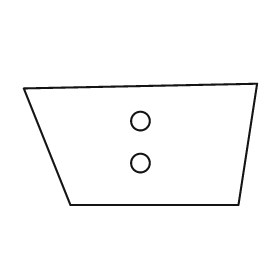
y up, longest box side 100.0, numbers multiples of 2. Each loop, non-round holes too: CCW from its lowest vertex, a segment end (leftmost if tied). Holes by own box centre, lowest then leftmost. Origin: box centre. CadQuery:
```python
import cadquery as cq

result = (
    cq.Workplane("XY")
    .moveTo(-30.0, -26.0)
    .lineTo(42.0, -26.0)
    .lineTo(50.0, 26.0)
    .lineTo(-50.0, 24.0)
    .close()
    .moveTo(0.0, -8.0)
    .circle(4.0)
    .moveTo(0.0, 10.0)
    .circle(4.0)
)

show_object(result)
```